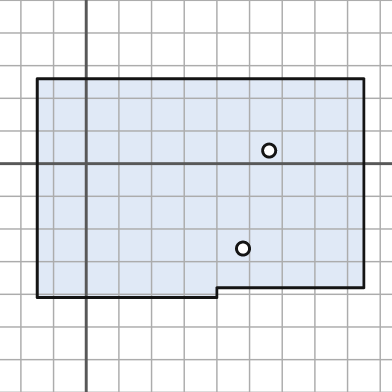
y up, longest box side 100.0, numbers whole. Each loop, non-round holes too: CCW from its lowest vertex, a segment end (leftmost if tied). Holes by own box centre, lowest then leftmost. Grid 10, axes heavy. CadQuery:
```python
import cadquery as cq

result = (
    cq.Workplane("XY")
    .moveTo(-15.0, -41.0)
    .lineTo(40.0, -41.0)
    .lineTo(40.0, -38.0)
    .lineTo(85.0, -38.0)
    .lineTo(85.0, 26.0)
    .lineTo(-15.0, 26.0)
    .close()
    .moveTo(48.0, -26.0)
    .circle(2.0)
    .moveTo(56.0, 4.0)
    .circle(2.0)
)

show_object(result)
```